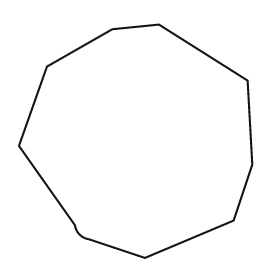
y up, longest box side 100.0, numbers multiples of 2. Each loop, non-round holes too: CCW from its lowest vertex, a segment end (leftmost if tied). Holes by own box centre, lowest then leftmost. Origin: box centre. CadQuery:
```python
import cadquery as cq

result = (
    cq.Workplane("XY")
    .moveTo(4.0, -50.0)
    .lineTo(42.0, -34.0)
    .lineTo(50.0, -10.0)
    .lineTo(48.0, 26.0)
    .lineTo(10.0, 50.0)
    .lineTo(-10.0, 48.0)
    .lineTo(-38.0, 32.0)
    .lineTo(-50.0, -2.0)
    .lineTo(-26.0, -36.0)
    .threePointArc((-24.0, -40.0), (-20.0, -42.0))
    .close()
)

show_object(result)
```